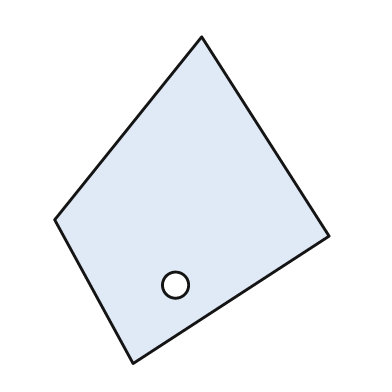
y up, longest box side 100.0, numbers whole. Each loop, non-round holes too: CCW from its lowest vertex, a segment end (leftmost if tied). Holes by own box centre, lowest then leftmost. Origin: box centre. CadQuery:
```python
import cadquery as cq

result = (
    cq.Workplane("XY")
    .moveTo(-18.0, -50.0)
    .lineTo(42.0, -11.0)
    .lineTo(3.0, 50.0)
    .lineTo(-42.0, -6.0)
    .close()
    .moveTo(-5.0, -26.0)
    .circle(4.0)
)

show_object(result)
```